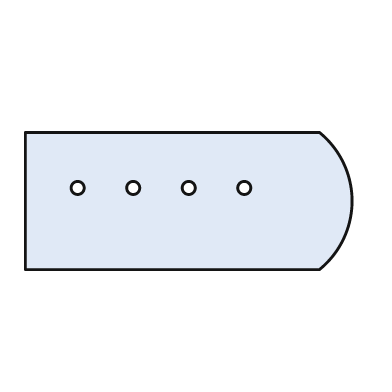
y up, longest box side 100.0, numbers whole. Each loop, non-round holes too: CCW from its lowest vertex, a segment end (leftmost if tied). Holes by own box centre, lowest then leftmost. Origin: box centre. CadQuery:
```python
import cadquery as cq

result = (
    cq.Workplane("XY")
    .moveTo(-50.0, -21.0)
    .lineTo(40.0, -21.0)
    .threePointArc((50.0, 0.0), (40.0, 21.0))
    .lineTo(-50.0, 21.0)
    .close()
    .moveTo(-34.0, 4.0)
    .circle(2.0)
    .moveTo(-17.0, 4.0)
    .circle(2.0)
    .moveTo(0.0, 4.0)
    .circle(2.0)
    .moveTo(17.0, 4.0)
    .circle(2.0)
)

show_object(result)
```